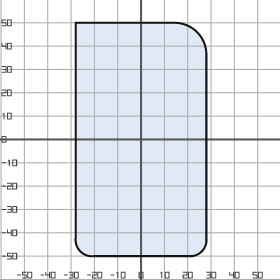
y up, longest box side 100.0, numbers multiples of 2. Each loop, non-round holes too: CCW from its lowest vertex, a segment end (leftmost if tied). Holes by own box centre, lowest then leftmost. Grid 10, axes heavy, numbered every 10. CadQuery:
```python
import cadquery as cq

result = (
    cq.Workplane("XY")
    .moveTo(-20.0, -50.0)
    .lineTo(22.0, -50.0)
    .threePointArc((26.0, -48.0), (28.0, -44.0))
    .lineTo(28.0, 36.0)
    .threePointArc((24.0, 46.0), (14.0, 50.0))
    .lineTo(-28.0, 50.0)
    .lineTo(-28.0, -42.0)
    .threePointArc((-26.0, -48.0), (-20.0, -50.0))
    .close()
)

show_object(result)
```